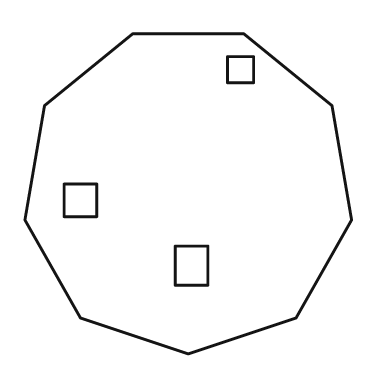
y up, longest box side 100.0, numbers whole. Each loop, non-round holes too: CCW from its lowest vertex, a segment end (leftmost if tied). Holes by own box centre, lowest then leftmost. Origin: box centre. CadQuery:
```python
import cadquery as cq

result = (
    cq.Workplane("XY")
    .moveTo(0.0, -49.0)
    .lineTo(33.0, -38.0)
    .lineTo(50.0, -8.0)
    .lineTo(44.0, 27.0)
    .lineTo(17.0, 49.0)
    .lineTo(-17.0, 49.0)
    .lineTo(-44.0, 27.0)
    .lineTo(-50.0, -8.0)
    .lineTo(-33.0, -38.0)
    .close()
    .moveTo(-4.0, -28.0)
    .lineTo(6.0, -28.0)
    .lineTo(6.0, -16.0)
    .lineTo(-4.0, -16.0)
    .close()
    .moveTo(-38.0, -7.0)
    .lineTo(-28.0, -7.0)
    .lineTo(-28.0, 3.0)
    .lineTo(-38.0, 3.0)
    .close()
    .moveTo(12.0, 34.0)
    .lineTo(20.0, 34.0)
    .lineTo(20.0, 42.0)
    .lineTo(12.0, 42.0)
    .close()
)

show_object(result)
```